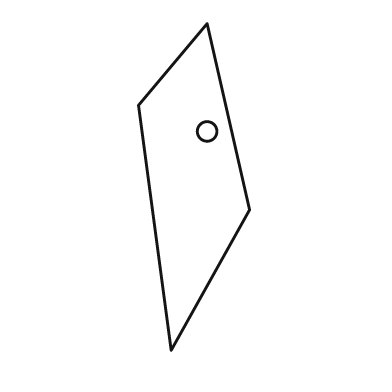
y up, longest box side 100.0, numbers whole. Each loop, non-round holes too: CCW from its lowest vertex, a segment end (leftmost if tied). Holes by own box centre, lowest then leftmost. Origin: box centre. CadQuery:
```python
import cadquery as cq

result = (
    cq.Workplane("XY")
    .moveTo(-7.0, -50.0)
    .lineTo(17.0, -7.0)
    .lineTo(4.0, 50.0)
    .lineTo(-17.0, 25.0)
    .close()
    .moveTo(4.0, 17.0)
    .circle(3.0)
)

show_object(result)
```